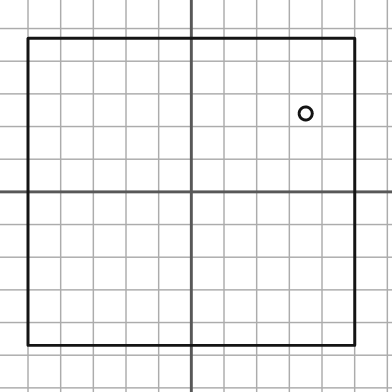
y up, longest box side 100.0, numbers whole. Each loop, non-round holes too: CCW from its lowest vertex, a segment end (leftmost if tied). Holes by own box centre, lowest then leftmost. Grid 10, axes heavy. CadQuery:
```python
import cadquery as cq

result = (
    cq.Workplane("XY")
    .moveTo(-50.0, -47.0)
    .lineTo(50.0, -47.0)
    .lineTo(50.0, 47.0)
    .lineTo(-50.0, 47.0)
    .close()
    .moveTo(35.0, 24.0)
    .circle(2.0)
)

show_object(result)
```